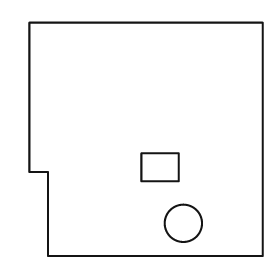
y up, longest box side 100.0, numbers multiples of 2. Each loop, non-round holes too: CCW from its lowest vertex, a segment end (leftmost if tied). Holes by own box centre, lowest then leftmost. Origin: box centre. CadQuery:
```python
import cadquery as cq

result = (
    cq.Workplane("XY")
    .moveTo(-42.0, -50.0)
    .lineTo(50.0, -50.0)
    .lineTo(50.0, 50.0)
    .lineTo(-50.0, 50.0)
    .lineTo(-50.0, -14.0)
    .lineTo(-42.0, -14.0)
    .close()
    .moveTo(16.0, -36.0)
    .circle(8.0)
    .moveTo(-2.0, -18.0)
    .lineTo(14.0, -18.0)
    .lineTo(14.0, -6.0)
    .lineTo(-2.0, -6.0)
    .close()
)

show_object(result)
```